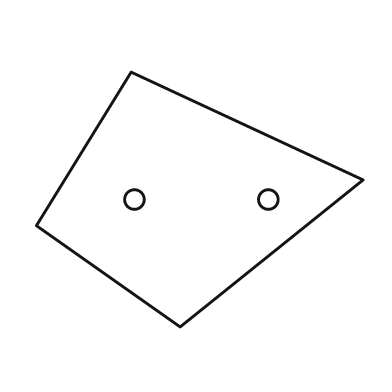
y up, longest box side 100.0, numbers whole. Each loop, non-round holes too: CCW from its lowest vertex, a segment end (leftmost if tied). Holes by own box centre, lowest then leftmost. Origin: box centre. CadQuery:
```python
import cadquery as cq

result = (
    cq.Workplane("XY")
    .moveTo(-6.0, -39.0)
    .lineTo(50.0, 6.0)
    .lineTo(-21.0, 39.0)
    .lineTo(-50.0, -8.0)
    .close()
    .moveTo(-20.0, 0.0)
    .circle(3.0)
    .moveTo(21.0, 0.0)
    .circle(3.0)
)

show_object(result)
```